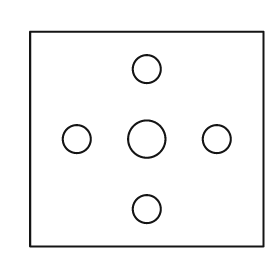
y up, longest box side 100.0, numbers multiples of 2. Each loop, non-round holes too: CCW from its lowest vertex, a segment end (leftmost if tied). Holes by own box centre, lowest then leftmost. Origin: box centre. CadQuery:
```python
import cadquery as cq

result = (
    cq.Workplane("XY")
    .moveTo(-50.0, -46.0)
    .lineTo(50.0, -46.0)
    .lineTo(50.0, 46.0)
    .lineTo(-50.0, 46.0)
    .close()
    .moveTo(0.0, -30.0)
    .circle(6.0)
    .moveTo(-30.0, 0.0)
    .circle(6.0)
    .moveTo(0.0, 0.0)
    .circle(8.0)
    .moveTo(30.0, 0.0)
    .circle(6.0)
    .moveTo(0.0, 30.0)
    .circle(6.0)
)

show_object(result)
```